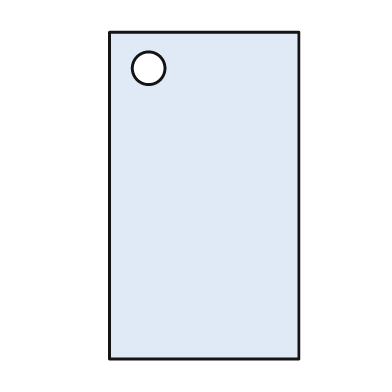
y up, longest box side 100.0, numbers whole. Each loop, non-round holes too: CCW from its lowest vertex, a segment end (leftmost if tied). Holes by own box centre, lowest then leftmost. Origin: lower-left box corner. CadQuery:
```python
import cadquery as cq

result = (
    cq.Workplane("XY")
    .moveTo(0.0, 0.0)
    .lineTo(58.0, 0.0)
    .lineTo(58.0, 100.0)
    .lineTo(0.0, 100.0)
    .close()
    .moveTo(12.0, 89.0)
    .circle(5.0)
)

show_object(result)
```